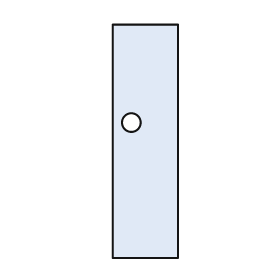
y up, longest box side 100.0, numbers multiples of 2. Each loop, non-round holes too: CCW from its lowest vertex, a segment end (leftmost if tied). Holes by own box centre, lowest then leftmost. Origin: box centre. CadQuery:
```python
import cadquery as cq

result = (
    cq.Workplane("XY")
    .moveTo(-14.0, -50.0)
    .lineTo(14.0, -50.0)
    .lineTo(14.0, 50.0)
    .lineTo(-14.0, 50.0)
    .close()
    .moveTo(-6.0, 8.0)
    .circle(4.0)
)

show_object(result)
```